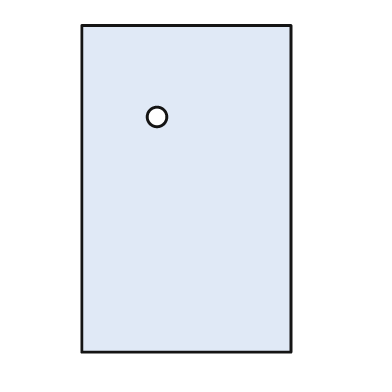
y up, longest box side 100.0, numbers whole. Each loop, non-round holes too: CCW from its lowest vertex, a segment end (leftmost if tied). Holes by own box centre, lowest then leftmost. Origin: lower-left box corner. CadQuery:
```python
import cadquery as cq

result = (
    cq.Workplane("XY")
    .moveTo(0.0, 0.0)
    .lineTo(64.0, 0.0)
    .lineTo(64.0, 100.0)
    .lineTo(0.0, 100.0)
    .close()
    .moveTo(23.0, 72.0)
    .circle(3.0)
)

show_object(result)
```